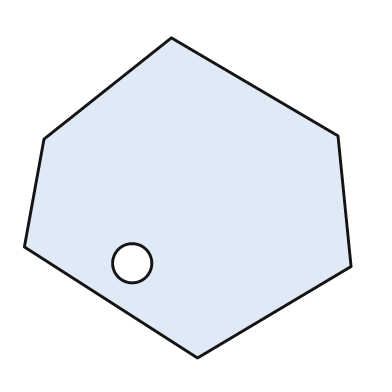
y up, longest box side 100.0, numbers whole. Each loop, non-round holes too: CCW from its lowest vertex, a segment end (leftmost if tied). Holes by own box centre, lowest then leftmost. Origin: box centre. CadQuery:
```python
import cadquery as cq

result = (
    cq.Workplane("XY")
    .moveTo(3.0, -49.0)
    .lineTo(50.0, -21.0)
    .lineTo(46.0, 19.0)
    .lineTo(-5.0, 49.0)
    .lineTo(-44.0, 18.0)
    .lineTo(-50.0, -15.0)
    .close()
    .moveTo(-17.0, -20.0)
    .circle(6.0)
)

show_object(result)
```